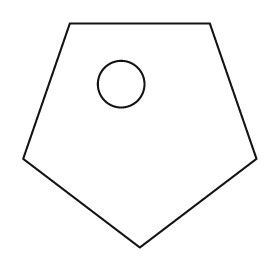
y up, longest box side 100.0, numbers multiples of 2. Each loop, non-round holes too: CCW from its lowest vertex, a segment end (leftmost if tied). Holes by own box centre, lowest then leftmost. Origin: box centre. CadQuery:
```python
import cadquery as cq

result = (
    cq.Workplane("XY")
    .moveTo(0.0, -48.0)
    .lineTo(50.0, -10.0)
    .lineTo(30.0, 48.0)
    .lineTo(-30.0, 48.0)
    .lineTo(-50.0, -10.0)
    .close()
    .moveTo(-8.0, 22.0)
    .circle(10.0)
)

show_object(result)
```